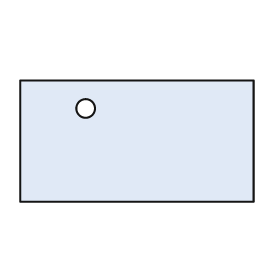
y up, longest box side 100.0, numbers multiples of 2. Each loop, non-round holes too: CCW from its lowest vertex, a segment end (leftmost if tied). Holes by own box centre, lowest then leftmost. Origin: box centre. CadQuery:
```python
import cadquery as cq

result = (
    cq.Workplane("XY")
    .moveTo(-50.0, -26.0)
    .lineTo(50.0, -26.0)
    .lineTo(50.0, 26.0)
    .lineTo(-50.0, 26.0)
    .close()
    .moveTo(-22.0, 14.0)
    .circle(4.0)
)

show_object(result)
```